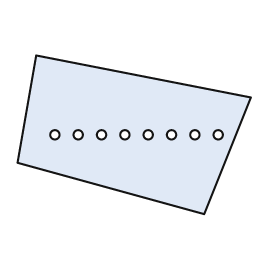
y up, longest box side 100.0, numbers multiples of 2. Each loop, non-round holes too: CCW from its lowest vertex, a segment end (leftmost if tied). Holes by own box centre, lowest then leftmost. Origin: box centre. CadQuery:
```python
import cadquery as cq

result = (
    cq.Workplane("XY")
    .moveTo(30.0, -34.0)
    .lineTo(50.0, 16.0)
    .lineTo(-42.0, 34.0)
    .lineTo(-50.0, -12.0)
    .close()
    .moveTo(-34.0, 0.0)
    .circle(2.0)
    .moveTo(-24.0, 0.0)
    .circle(2.0)
    .moveTo(-14.0, 0.0)
    .circle(2.0)
    .moveTo(-4.0, 0.0)
    .circle(2.0)
    .moveTo(6.0, 0.0)
    .circle(2.0)
    .moveTo(16.0, 0.0)
    .circle(2.0)
    .moveTo(26.0, 0.0)
    .circle(2.0)
    .moveTo(36.0, 0.0)
    .circle(2.0)
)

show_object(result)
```